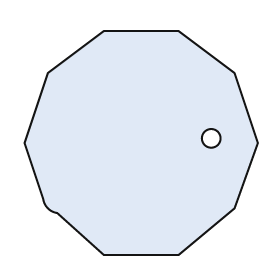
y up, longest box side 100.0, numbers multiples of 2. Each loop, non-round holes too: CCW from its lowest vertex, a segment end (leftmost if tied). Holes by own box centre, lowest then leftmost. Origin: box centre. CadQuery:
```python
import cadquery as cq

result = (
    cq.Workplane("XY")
    .moveTo(-16.0, -48.0)
    .lineTo(16.0, -48.0)
    .lineTo(40.0, -28.0)
    .lineTo(50.0, 0.0)
    .lineTo(40.0, 30.0)
    .lineTo(16.0, 48.0)
    .lineTo(-16.0, 48.0)
    .lineTo(-40.0, 30.0)
    .lineTo(-50.0, 0.0)
    .lineTo(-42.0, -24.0)
    .threePointArc((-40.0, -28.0), (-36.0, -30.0))
    .close()
    .moveTo(30.0, 2.0)
    .circle(4.0)
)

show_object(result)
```